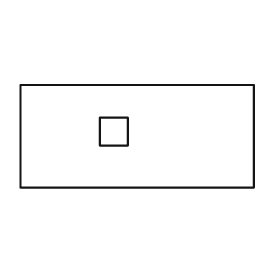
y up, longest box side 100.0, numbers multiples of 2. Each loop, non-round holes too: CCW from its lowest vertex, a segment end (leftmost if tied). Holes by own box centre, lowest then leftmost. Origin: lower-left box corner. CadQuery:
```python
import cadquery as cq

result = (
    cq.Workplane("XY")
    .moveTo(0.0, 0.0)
    .lineTo(100.0, 0.0)
    .lineTo(100.0, 44.0)
    .lineTo(0.0, 44.0)
    .close()
    .moveTo(34.0, 18.0)
    .lineTo(46.0, 18.0)
    .lineTo(46.0, 30.0)
    .lineTo(34.0, 30.0)
    .close()
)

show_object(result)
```